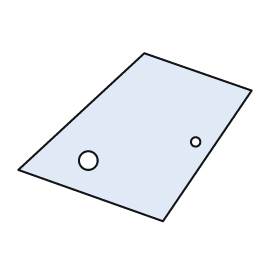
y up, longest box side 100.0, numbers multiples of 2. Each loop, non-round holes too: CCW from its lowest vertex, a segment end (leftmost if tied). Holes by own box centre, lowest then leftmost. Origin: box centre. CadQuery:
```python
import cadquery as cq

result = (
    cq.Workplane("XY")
    .moveTo(12.0, -36.0)
    .lineTo(50.0, 20.0)
    .lineTo(4.0, 36.0)
    .lineTo(-50.0, -14.0)
    .close()
    .moveTo(-20.0, -10.0)
    .circle(4.0)
    .moveTo(26.0, -2.0)
    .circle(2.0)
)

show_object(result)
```